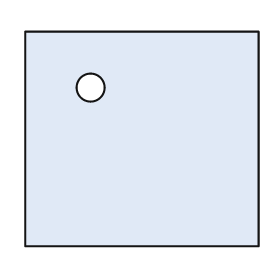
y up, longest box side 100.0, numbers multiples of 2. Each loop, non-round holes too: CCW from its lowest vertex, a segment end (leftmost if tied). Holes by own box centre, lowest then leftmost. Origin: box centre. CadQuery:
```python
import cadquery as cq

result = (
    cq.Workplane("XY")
    .moveTo(-50.0, -46.0)
    .lineTo(50.0, -46.0)
    .lineTo(50.0, 46.0)
    .lineTo(-50.0, 46.0)
    .close()
    .moveTo(-22.0, 22.0)
    .circle(6.0)
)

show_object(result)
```